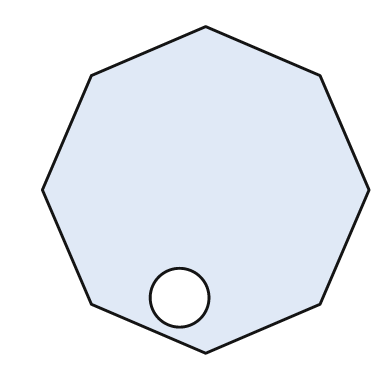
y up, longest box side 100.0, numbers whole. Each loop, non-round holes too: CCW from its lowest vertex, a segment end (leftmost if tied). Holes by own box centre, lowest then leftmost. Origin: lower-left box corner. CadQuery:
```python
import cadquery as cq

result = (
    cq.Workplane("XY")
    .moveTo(50.0, 0.0)
    .lineTo(85.0, 15.0)
    .lineTo(100.0, 50.0)
    .lineTo(85.0, 85.0)
    .lineTo(50.0, 100.0)
    .lineTo(15.0, 85.0)
    .lineTo(0.0, 50.0)
    .lineTo(15.0, 15.0)
    .close()
    .moveTo(42.0, 17.0)
    .circle(9.0)
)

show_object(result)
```